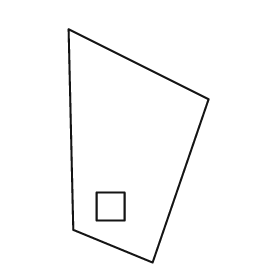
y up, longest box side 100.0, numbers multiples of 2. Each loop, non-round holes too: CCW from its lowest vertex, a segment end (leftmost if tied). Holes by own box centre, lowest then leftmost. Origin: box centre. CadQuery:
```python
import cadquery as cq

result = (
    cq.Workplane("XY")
    .moveTo(6.0, -50.0)
    .lineTo(30.0, 20.0)
    .lineTo(-30.0, 50.0)
    .lineTo(-28.0, -36.0)
    .close()
    .moveTo(-18.0, -32.0)
    .lineTo(-6.0, -32.0)
    .lineTo(-6.0, -20.0)
    .lineTo(-18.0, -20.0)
    .close()
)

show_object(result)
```